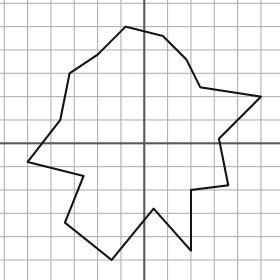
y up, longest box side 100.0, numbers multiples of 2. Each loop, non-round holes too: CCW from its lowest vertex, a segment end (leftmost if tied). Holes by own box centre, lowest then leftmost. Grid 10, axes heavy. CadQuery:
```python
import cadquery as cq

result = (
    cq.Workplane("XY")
    .moveTo(-14.0, -50.0)
    .lineTo(4.0, -28.0)
    .lineTo(20.0, -46.0)
    .lineTo(20.0, -20.0)
    .lineTo(36.0, -18.0)
    .lineTo(32.0, 2.0)
    .lineTo(50.0, 20.0)
    .lineTo(24.0, 24.0)
    .lineTo(18.0, 36.0)
    .lineTo(8.0, 46.0)
    .lineTo(-8.0, 50.0)
    .lineTo(-20.0, 38.0)
    .lineTo(-32.0, 30.0)
    .lineTo(-36.0, 10.0)
    .lineTo(-50.0, -8.0)
    .lineTo(-26.0, -14.0)
    .lineTo(-34.0, -34.0)
    .close()
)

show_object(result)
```